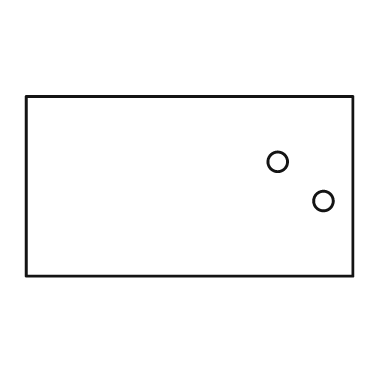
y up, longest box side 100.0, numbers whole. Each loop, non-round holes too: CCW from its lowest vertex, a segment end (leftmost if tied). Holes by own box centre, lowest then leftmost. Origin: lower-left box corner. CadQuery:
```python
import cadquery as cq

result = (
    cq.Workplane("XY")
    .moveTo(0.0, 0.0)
    .lineTo(100.0, 0.0)
    .lineTo(100.0, 55.0)
    .lineTo(0.0, 55.0)
    .close()
    .moveTo(91.0, 23.0)
    .circle(3.0)
    .moveTo(77.0, 35.0)
    .circle(3.0)
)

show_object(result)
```